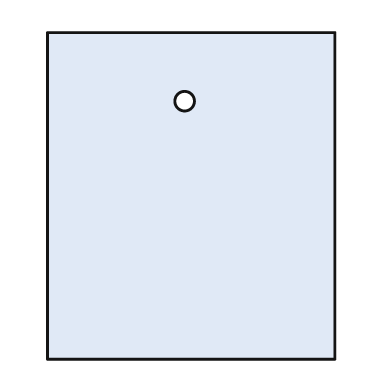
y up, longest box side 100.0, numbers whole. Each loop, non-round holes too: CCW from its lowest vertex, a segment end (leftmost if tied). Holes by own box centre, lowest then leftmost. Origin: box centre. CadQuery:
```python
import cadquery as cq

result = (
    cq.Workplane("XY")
    .moveTo(-44.0, -50.0)
    .lineTo(44.0, -50.0)
    .lineTo(44.0, 50.0)
    .lineTo(-44.0, 50.0)
    .close()
    .moveTo(-2.0, 29.0)
    .circle(3.0)
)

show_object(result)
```